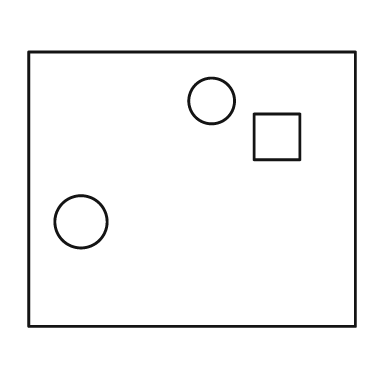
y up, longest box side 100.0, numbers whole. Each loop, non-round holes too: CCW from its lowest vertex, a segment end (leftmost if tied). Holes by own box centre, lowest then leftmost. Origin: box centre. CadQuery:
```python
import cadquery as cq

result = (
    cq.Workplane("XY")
    .moveTo(-50.0, -42.0)
    .lineTo(50.0, -42.0)
    .lineTo(50.0, 42.0)
    .lineTo(-50.0, 42.0)
    .close()
    .moveTo(-34.0, -10.0)
    .circle(8.0)
    .moveTo(19.0, 9.0)
    .lineTo(33.0, 9.0)
    .lineTo(33.0, 23.0)
    .lineTo(19.0, 23.0)
    .close()
    .moveTo(6.0, 27.0)
    .circle(7.0)
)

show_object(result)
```